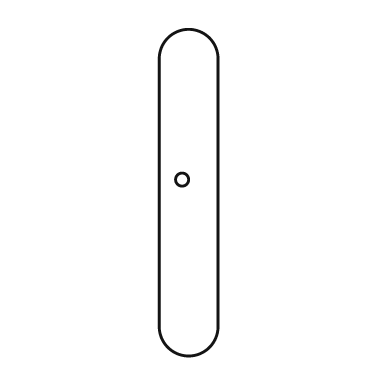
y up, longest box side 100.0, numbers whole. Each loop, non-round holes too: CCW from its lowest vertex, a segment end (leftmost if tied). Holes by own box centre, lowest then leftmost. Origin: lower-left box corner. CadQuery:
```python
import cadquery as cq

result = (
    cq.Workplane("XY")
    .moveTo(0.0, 9.0)
    .threePointArc((9.0, 0.0), (18.0, 9.0))
    .lineTo(18.0, 91.0)
    .threePointArc((9.0, 100.0), (0.0, 91.0))
    .close()
    .moveTo(7.0, 54.0)
    .circle(2.0)
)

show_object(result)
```